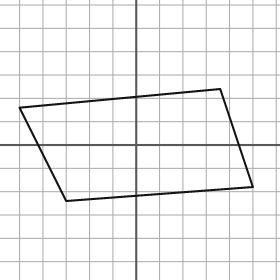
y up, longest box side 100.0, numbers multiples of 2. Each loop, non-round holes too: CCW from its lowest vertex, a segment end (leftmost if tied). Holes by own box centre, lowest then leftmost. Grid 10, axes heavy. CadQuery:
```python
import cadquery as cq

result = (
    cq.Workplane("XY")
    .moveTo(-30.0, -24.0)
    .lineTo(50.0, -18.0)
    .lineTo(36.0, 24.0)
    .lineTo(-50.0, 16.0)
    .close()
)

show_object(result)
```